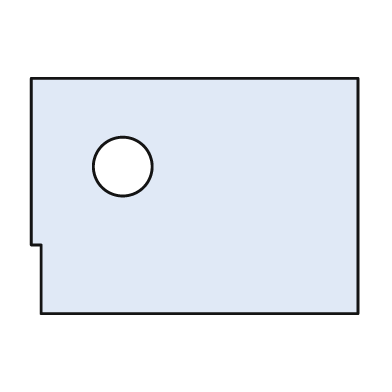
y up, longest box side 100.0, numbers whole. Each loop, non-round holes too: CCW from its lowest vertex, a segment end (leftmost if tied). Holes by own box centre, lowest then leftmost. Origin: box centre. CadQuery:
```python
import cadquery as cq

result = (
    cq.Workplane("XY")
    .moveTo(-47.0, -36.0)
    .lineTo(50.0, -36.0)
    .lineTo(50.0, 36.0)
    .lineTo(-50.0, 36.0)
    .lineTo(-50.0, -15.0)
    .lineTo(-47.0, -15.0)
    .close()
    .moveTo(-22.0, 9.0)
    .circle(9.0)
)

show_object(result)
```